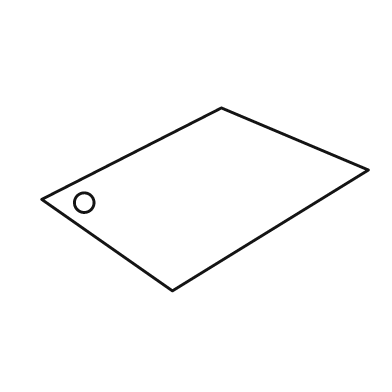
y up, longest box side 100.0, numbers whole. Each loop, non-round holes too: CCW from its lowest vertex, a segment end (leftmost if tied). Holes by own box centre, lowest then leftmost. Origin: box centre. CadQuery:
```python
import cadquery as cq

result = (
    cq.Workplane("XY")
    .moveTo(-10.0, -28.0)
    .lineTo(50.0, 9.0)
    .lineTo(5.0, 28.0)
    .lineTo(-50.0, 0.0)
    .close()
    .moveTo(-37.0, -1.0)
    .circle(3.0)
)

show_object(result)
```